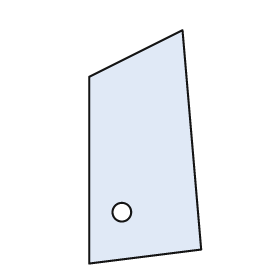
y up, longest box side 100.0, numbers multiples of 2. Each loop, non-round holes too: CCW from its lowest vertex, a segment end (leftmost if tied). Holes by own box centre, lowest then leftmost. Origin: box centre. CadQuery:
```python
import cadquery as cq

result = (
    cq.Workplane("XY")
    .moveTo(-24.0, -50.0)
    .lineTo(24.0, -44.0)
    .lineTo(16.0, 50.0)
    .lineTo(-24.0, 30.0)
    .close()
    .moveTo(-10.0, -28.0)
    .circle(4.0)
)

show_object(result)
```